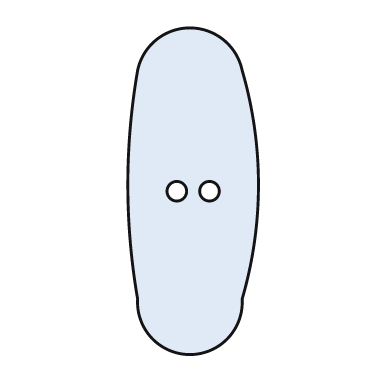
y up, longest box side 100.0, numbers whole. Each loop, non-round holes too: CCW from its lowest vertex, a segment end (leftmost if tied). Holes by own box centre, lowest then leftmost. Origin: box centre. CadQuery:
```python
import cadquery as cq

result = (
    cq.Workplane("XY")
    .moveTo(-17.0, -33.0)
    .threePointArc((-1.0, -50.0), (15.0, -33.0))
    .threePointArc((20.0, 2.0), (15.0, 37.0))
    .threePointArc((-1.0, 50.0), (-17.0, 37.0))
    .threePointArc((-20.0, 2.0), (-17.0, -33.0))
    .close()
    .moveTo(-5.0, 0.0)
    .circle(3.0)
    .moveTo(5.0, 0.0)
    .circle(3.0)
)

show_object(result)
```